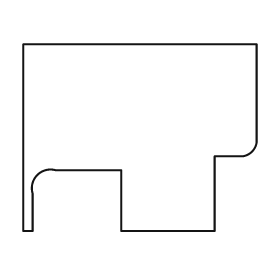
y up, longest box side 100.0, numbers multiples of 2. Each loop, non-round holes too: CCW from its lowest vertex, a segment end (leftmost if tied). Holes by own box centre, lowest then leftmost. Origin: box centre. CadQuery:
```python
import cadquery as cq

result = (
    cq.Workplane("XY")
    .moveTo(-50.0, -40.0)
    .lineTo(-46.0, -40.0)
    .lineTo(-46.0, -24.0)
    .threePointArc((-44.0, -16.0), (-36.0, -14.0))
    .lineTo(-8.0, -14.0)
    .lineTo(-8.0, -40.0)
    .lineTo(32.0, -40.0)
    .lineTo(32.0, -8.0)
    .lineTo(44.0, -8.0)
    .threePointArc((48.0, -6.0), (50.0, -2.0))
    .lineTo(50.0, 40.0)
    .lineTo(-50.0, 40.0)
    .close()
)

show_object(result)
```